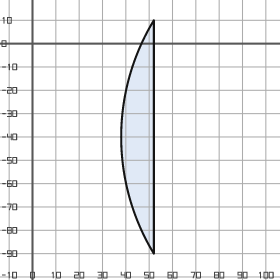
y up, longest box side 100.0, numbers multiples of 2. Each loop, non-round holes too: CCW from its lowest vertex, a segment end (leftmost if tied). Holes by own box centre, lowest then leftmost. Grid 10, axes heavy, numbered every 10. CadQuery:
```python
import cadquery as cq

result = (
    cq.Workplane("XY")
    .moveTo(52.0, -90.0)
    .lineTo(52.0, 10.0)
    .threePointArc((38.0, -40.0), (52.0, -90.0))
    .close()
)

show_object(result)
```